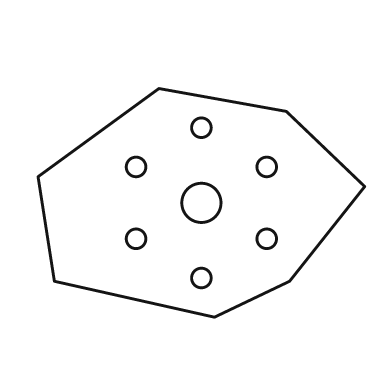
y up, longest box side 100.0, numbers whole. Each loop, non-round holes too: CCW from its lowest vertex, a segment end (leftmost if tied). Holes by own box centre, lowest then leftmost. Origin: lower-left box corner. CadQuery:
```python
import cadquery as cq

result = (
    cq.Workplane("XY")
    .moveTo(54.0, 0.0)
    .lineTo(77.0, 11.0)
    .lineTo(100.0, 40.0)
    .lineTo(76.0, 63.0)
    .lineTo(37.0, 70.0)
    .lineTo(0.0, 43.0)
    .lineTo(5.0, 11.0)
    .close()
    .moveTo(50.0, 12.0)
    .circle(3.0)
    .moveTo(30.0, 24.0)
    .circle(3.0)
    .moveTo(70.0, 24.0)
    .circle(3.0)
    .moveTo(50.0, 35.0)
    .circle(6.0)
    .moveTo(30.0, 46.0)
    .circle(3.0)
    .moveTo(70.0, 46.0)
    .circle(3.0)
    .moveTo(50.0, 58.0)
    .circle(3.0)
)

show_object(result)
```